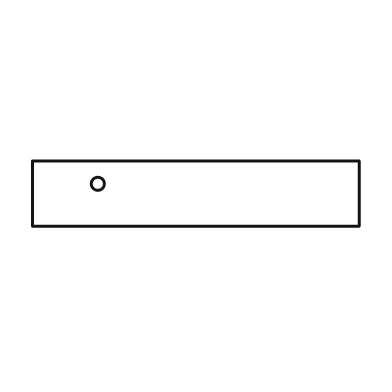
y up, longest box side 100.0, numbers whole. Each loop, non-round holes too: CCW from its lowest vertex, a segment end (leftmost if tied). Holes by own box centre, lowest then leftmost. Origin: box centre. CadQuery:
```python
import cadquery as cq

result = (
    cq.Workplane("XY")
    .moveTo(-50.0, -10.0)
    .lineTo(50.0, -10.0)
    .lineTo(50.0, 10.0)
    .lineTo(-50.0, 10.0)
    .close()
    .moveTo(-30.0, 3.0)
    .circle(2.0)
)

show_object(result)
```